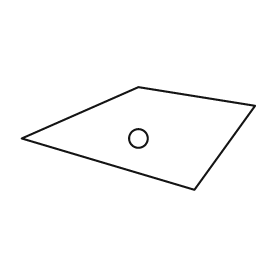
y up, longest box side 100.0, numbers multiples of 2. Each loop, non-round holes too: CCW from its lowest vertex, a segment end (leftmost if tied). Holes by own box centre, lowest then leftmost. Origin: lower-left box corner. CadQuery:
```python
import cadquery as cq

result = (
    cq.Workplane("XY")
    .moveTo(74.0, 0.0)
    .lineTo(100.0, 36.0)
    .lineTo(50.0, 44.0)
    .lineTo(0.0, 22.0)
    .close()
    .moveTo(50.0, 22.0)
    .circle(4.0)
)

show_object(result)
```